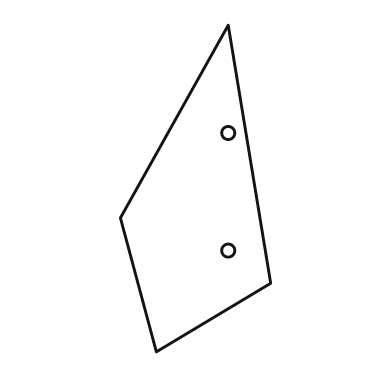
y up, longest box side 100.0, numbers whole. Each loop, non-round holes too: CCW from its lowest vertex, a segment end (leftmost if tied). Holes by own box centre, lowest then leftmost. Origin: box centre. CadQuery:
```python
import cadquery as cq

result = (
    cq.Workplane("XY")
    .moveTo(-12.0, -50.0)
    .lineTo(23.0, -29.0)
    .lineTo(10.0, 50.0)
    .lineTo(-23.0, -9.0)
    .close()
    .moveTo(10.0, -19.0)
    .circle(2.0)
    .moveTo(10.0, 17.0)
    .circle(2.0)
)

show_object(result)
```